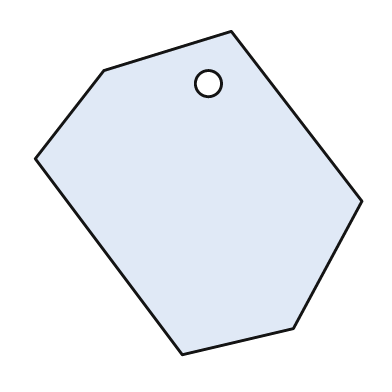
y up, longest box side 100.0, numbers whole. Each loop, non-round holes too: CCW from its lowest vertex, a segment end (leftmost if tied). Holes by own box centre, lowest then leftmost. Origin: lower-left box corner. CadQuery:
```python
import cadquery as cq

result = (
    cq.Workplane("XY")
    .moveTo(45.0, 0.0)
    .lineTo(79.0, 8.0)
    .lineTo(100.0, 47.0)
    .lineTo(60.0, 99.0)
    .lineTo(21.0, 87.0)
    .lineTo(0.0, 60.0)
    .close()
    .moveTo(53.0, 83.0)
    .circle(4.0)
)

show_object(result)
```